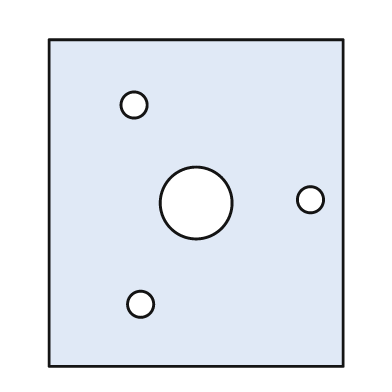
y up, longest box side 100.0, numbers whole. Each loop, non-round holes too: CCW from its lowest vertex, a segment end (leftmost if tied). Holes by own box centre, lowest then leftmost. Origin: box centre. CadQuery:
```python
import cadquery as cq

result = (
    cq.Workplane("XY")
    .moveTo(-45.0, -50.0)
    .lineTo(45.0, -50.0)
    .lineTo(45.0, 50.0)
    .lineTo(-45.0, 50.0)
    .close()
    .moveTo(-17.0, -31.0)
    .circle(4.0)
    .moveTo(0.0, 0.0)
    .circle(11.0)
    .moveTo(35.0, 1.0)
    .circle(4.0)
    .moveTo(-19.0, 30.0)
    .circle(4.0)
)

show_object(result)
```